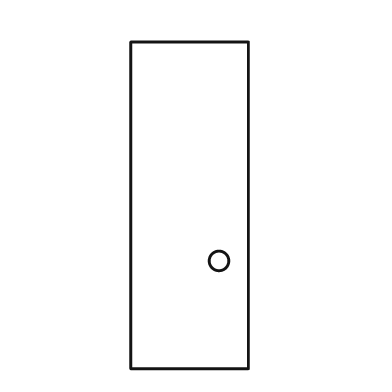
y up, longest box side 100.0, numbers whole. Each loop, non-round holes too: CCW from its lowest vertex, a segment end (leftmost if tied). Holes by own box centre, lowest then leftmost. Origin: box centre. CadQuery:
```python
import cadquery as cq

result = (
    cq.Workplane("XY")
    .moveTo(-18.0, -50.0)
    .lineTo(18.0, -50.0)
    .lineTo(18.0, 50.0)
    .lineTo(-18.0, 50.0)
    .close()
    .moveTo(9.0, -17.0)
    .circle(3.0)
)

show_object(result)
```